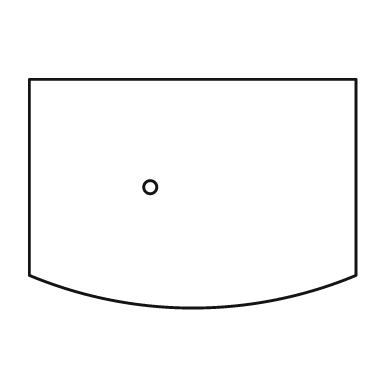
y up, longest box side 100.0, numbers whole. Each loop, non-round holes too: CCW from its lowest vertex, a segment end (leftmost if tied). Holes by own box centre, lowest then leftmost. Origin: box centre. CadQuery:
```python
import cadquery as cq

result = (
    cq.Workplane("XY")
    .moveTo(-50.0, -25.0)
    .threePointArc((0.0, -35.0), (50.0, -25.0))
    .lineTo(50.0, 35.0)
    .lineTo(-50.0, 35.0)
    .close()
    .moveTo(-13.0, 2.0)
    .circle(2.0)
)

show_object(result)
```